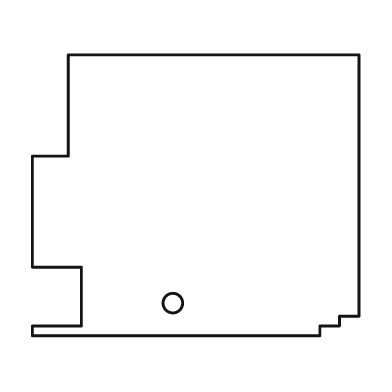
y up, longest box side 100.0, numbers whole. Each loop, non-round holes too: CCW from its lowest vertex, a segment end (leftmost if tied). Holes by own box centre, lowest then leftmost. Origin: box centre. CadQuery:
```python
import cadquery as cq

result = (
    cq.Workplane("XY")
    .moveTo(-50.0, -43.0)
    .lineTo(38.0, -43.0)
    .lineTo(38.0, -40.0)
    .lineTo(44.0, -40.0)
    .lineTo(44.0, -37.0)
    .lineTo(50.0, -37.0)
    .lineTo(50.0, 43.0)
    .lineTo(-39.0, 43.0)
    .lineTo(-39.0, 12.0)
    .lineTo(-50.0, 12.0)
    .lineTo(-50.0, -22.0)
    .lineTo(-35.0, -22.0)
    .lineTo(-35.0, -40.0)
    .lineTo(-50.0, -40.0)
    .close()
    .moveTo(-7.0, -33.0)
    .circle(3.0)
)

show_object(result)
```